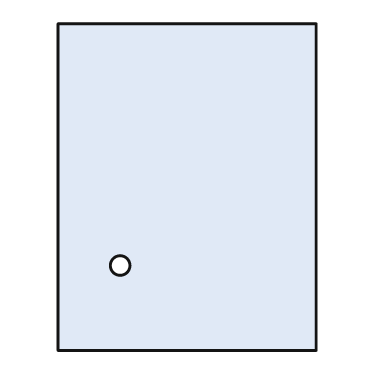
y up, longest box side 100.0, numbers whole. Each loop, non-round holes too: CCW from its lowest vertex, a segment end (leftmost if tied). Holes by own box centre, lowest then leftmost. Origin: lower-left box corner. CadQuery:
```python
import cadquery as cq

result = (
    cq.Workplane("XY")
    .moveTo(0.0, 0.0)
    .lineTo(79.0, 0.0)
    .lineTo(79.0, 100.0)
    .lineTo(0.0, 100.0)
    .close()
    .moveTo(19.0, 26.0)
    .circle(3.0)
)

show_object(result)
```